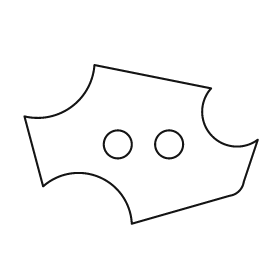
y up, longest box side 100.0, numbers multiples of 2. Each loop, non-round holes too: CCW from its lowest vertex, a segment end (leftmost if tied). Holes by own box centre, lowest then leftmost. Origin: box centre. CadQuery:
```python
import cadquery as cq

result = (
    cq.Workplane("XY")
    .moveTo(-4.0, -34.0)
    .lineTo(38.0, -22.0)
    .threePointArc((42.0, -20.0), (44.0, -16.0))
    .lineTo(50.0, 2.0)
    .threePointArc((30.0, 4.0), (30.0, 24.0))
    .lineTo(-20.0, 34.0)
    .threePointArc((-30.0, 16.0), (-50.0, 12.0))
    .lineTo(-42.0, -18.0)
    .threePointArc((-18.0, -14.0), (-4.0, -34.0))
    .close()
    .moveTo(-10.0, 0.0)
    .circle(6.0)
    .moveTo(12.0, 0.0)
    .circle(6.0)
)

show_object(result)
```